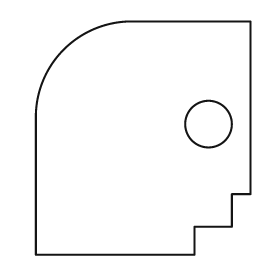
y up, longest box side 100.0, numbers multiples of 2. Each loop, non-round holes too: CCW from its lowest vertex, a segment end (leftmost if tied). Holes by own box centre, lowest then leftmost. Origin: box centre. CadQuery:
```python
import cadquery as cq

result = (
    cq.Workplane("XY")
    .moveTo(-46.0, -50.0)
    .lineTo(22.0, -50.0)
    .lineTo(22.0, -38.0)
    .lineTo(38.0, -38.0)
    .lineTo(38.0, -24.0)
    .lineTo(46.0, -24.0)
    .lineTo(46.0, 50.0)
    .lineTo(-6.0, 50.0)
    .threePointArc((-34.0, 38.0), (-46.0, 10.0))
    .close()
    .moveTo(28.0, 6.0)
    .circle(10.0)
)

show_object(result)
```